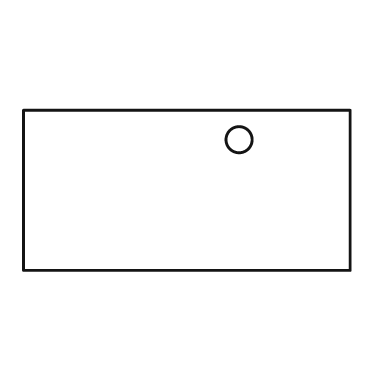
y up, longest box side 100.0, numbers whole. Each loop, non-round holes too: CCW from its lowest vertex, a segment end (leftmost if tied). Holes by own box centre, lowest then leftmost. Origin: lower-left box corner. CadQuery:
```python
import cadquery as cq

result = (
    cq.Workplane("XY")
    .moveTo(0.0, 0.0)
    .lineTo(100.0, 0.0)
    .lineTo(100.0, 49.0)
    .lineTo(0.0, 49.0)
    .close()
    .moveTo(66.0, 40.0)
    .circle(4.0)
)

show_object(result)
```